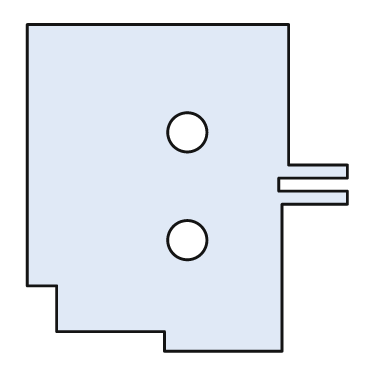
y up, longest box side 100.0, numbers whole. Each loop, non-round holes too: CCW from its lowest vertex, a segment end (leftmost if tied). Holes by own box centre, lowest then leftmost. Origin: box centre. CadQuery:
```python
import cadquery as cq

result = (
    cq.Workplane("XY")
    .moveTo(-7.0, -50.0)
    .lineTo(29.0, -50.0)
    .lineTo(29.0, -5.0)
    .lineTo(49.0, -5.0)
    .lineTo(49.0, -1.0)
    .lineTo(28.0, -1.0)
    .lineTo(28.0, 3.0)
    .lineTo(49.0, 3.0)
    .lineTo(49.0, 7.0)
    .lineTo(31.0, 7.0)
    .lineTo(31.0, 50.0)
    .lineTo(-49.0, 50.0)
    .lineTo(-49.0, -30.0)
    .lineTo(-40.0, -30.0)
    .lineTo(-40.0, -44.0)
    .lineTo(-7.0, -44.0)
    .close()
    .moveTo(0.0, -16.0)
    .circle(6.0)
    .moveTo(0.0, 17.0)
    .circle(6.0)
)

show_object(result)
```